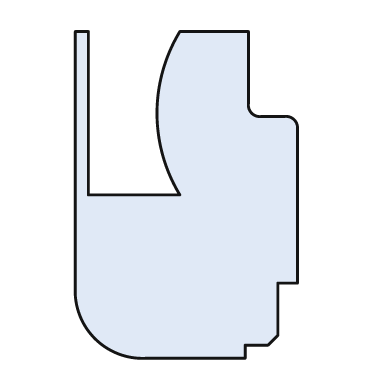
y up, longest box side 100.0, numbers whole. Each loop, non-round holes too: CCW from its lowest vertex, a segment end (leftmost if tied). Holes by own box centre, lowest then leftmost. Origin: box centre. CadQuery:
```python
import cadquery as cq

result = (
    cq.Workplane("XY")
    .moveTo(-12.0, -50.0)
    .lineTo(18.0, -50.0)
    .lineTo(18.0, -46.0)
    .lineTo(25.0, -46.0)
    .lineTo(28.0, -43.0)
    .lineTo(28.0, -27.0)
    .lineTo(34.0, -27.0)
    .lineTo(34.0, 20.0)
    .threePointArc((33.0, 23.0), (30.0, 24.0))
    .lineTo(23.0, 24.0)
    .threePointArc((20.0, 25.0), (19.0, 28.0))
    .lineTo(19.0, 50.0)
    .lineTo(-2.0, 50.0)
    .threePointArc((-9.0, 25.0), (-2.0, 0.0))
    .lineTo(-30.0, 0.0)
    .lineTo(-30.0, 50.0)
    .lineTo(-34.0, 50.0)
    .lineTo(-34.0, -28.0)
    .threePointArc((-28.0, -44.0), (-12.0, -50.0))
    .close()
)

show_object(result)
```